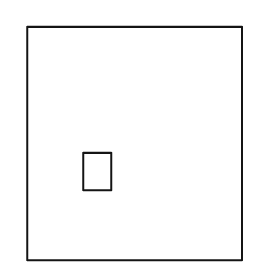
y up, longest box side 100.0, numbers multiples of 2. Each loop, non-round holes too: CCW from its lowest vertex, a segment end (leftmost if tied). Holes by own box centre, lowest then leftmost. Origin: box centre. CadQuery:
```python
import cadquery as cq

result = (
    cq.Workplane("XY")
    .moveTo(-46.0, -50.0)
    .lineTo(46.0, -50.0)
    .lineTo(46.0, 50.0)
    .lineTo(-46.0, 50.0)
    .close()
    .moveTo(-22.0, -20.0)
    .lineTo(-10.0, -20.0)
    .lineTo(-10.0, -4.0)
    .lineTo(-22.0, -4.0)
    .close()
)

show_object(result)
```